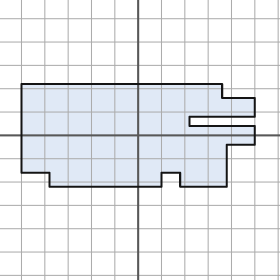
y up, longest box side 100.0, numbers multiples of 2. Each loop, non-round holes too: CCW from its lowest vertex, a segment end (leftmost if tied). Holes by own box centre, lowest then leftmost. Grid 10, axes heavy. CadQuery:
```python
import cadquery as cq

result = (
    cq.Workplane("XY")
    .moveTo(-38.0, -22.0)
    .lineTo(10.0, -22.0)
    .lineTo(10.0, -16.0)
    .lineTo(18.0, -16.0)
    .lineTo(18.0, -22.0)
    .lineTo(38.0, -22.0)
    .lineTo(38.0, -4.0)
    .lineTo(50.0, -4.0)
    .lineTo(50.0, 4.0)
    .lineTo(22.0, 4.0)
    .lineTo(22.0, 8.0)
    .lineTo(50.0, 8.0)
    .lineTo(50.0, 16.0)
    .lineTo(36.0, 16.0)
    .lineTo(36.0, 22.0)
    .lineTo(-50.0, 22.0)
    .lineTo(-50.0, -16.0)
    .lineTo(-38.0, -16.0)
    .close()
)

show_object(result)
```